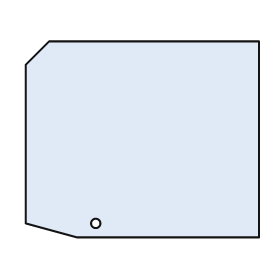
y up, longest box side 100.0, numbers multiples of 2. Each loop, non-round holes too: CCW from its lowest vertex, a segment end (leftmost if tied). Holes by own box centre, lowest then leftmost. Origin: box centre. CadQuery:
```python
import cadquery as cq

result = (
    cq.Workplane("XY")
    .moveTo(-28.0, -42.0)
    .lineTo(50.0, -42.0)
    .lineTo(50.0, 42.0)
    .lineTo(-40.0, 42.0)
    .lineTo(-50.0, 32.0)
    .lineTo(-50.0, -36.0)
    .close()
    .moveTo(-20.0, -36.0)
    .circle(2.0)
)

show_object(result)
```